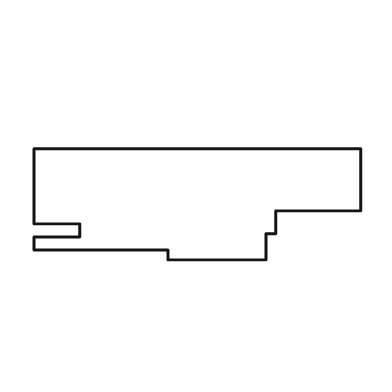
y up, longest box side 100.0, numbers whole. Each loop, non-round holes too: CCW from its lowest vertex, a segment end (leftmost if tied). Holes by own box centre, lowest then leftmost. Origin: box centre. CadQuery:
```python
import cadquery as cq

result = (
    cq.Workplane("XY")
    .moveTo(-9.0, -17.0)
    .lineTo(21.0, -17.0)
    .lineTo(21.0, -9.0)
    .lineTo(24.0, -9.0)
    .lineTo(24.0, -2.0)
    .lineTo(50.0, -2.0)
    .lineTo(50.0, 17.0)
    .lineTo(-50.0, 17.0)
    .lineTo(-50.0, -6.0)
    .lineTo(-36.0, -6.0)
    .lineTo(-36.0, -10.0)
    .lineTo(-50.0, -10.0)
    .lineTo(-50.0, -14.0)
    .lineTo(-9.0, -14.0)
    .close()
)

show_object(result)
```